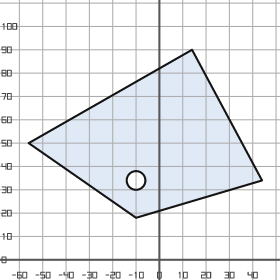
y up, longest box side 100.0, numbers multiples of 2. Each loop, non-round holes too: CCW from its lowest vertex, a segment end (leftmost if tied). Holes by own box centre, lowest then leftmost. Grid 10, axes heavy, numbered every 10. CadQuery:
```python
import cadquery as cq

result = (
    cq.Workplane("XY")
    .moveTo(-10.0, 18.0)
    .lineTo(44.0, 34.0)
    .lineTo(14.0, 90.0)
    .lineTo(-56.0, 50.0)
    .close()
    .moveTo(-10.0, 34.0)
    .circle(4.0)
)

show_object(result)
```